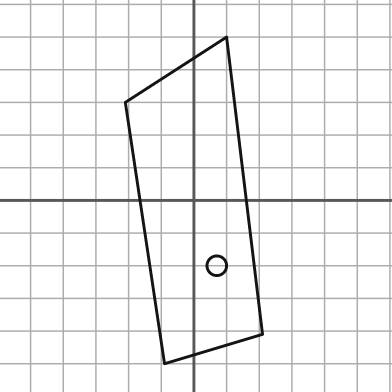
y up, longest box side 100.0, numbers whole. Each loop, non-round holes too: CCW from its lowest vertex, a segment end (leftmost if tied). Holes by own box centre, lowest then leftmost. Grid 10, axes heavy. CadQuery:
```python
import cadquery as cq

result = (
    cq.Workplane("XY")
    .moveTo(-9.0, -50.0)
    .lineTo(21.0, -41.0)
    .lineTo(10.0, 50.0)
    .lineTo(-21.0, 30.0)
    .close()
    .moveTo(7.0, -20.0)
    .circle(3.0)
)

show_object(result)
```